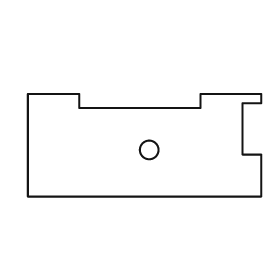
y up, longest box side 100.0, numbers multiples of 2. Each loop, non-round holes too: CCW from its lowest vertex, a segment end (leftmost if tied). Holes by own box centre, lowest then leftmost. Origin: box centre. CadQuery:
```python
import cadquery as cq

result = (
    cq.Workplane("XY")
    .moveTo(-50.0, -22.0)
    .lineTo(50.0, -22.0)
    .lineTo(50.0, -4.0)
    .lineTo(42.0, -4.0)
    .lineTo(42.0, 18.0)
    .lineTo(50.0, 18.0)
    .lineTo(50.0, 22.0)
    .lineTo(24.0, 22.0)
    .lineTo(24.0, 16.0)
    .lineTo(-28.0, 16.0)
    .lineTo(-28.0, 22.0)
    .lineTo(-50.0, 22.0)
    .close()
    .moveTo(2.0, -2.0)
    .circle(4.0)
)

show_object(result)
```